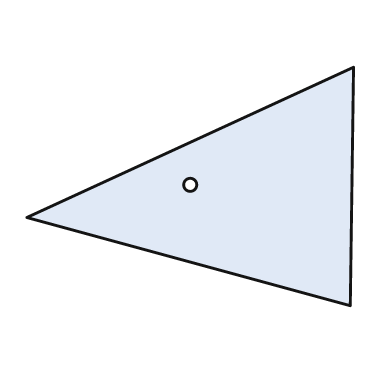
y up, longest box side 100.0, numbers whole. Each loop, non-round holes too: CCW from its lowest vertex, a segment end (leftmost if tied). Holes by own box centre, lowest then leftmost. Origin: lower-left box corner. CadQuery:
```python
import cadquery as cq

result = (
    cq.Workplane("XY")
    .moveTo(99.0, 0.0)
    .lineTo(100.0, 73.0)
    .lineTo(0.0, 27.0)
    .close()
    .moveTo(50.0, 37.0)
    .circle(2.0)
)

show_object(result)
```